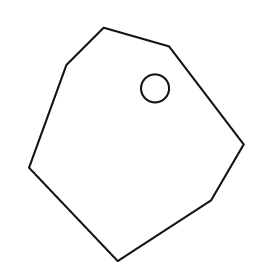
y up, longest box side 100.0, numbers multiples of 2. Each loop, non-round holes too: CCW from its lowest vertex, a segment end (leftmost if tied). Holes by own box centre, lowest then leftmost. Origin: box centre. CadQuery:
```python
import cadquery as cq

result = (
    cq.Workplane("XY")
    .moveTo(-8.0, -50.0)
    .lineTo(32.0, -24.0)
    .lineTo(46.0, 0.0)
    .lineTo(14.0, 42.0)
    .lineTo(-14.0, 50.0)
    .lineTo(-30.0, 34.0)
    .lineTo(-46.0, -10.0)
    .close()
    .moveTo(8.0, 24.0)
    .circle(6.0)
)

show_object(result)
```